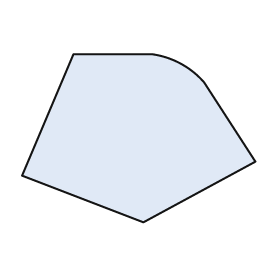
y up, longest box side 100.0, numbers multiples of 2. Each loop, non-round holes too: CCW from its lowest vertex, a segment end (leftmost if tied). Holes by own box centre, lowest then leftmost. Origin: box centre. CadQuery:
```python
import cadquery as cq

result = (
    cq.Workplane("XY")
    .moveTo(2.0, -36.0)
    .lineTo(50.0, -10.0)
    .lineTo(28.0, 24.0)
    .threePointArc((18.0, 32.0), (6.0, 36.0))
    .lineTo(-28.0, 36.0)
    .lineTo(-50.0, -16.0)
    .close()
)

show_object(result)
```